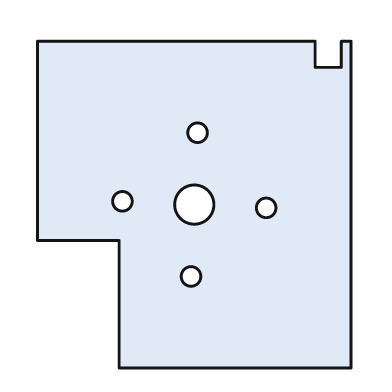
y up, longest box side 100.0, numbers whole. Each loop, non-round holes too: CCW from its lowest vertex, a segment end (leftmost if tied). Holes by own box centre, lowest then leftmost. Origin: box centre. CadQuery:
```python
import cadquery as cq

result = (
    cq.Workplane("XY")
    .moveTo(-23.0, -50.0)
    .lineTo(48.0, -50.0)
    .lineTo(48.0, 50.0)
    .lineTo(45.0, 50.0)
    .lineTo(45.0, 42.0)
    .lineTo(37.0, 42.0)
    .lineTo(37.0, 50.0)
    .lineTo(-48.0, 50.0)
    .lineTo(-48.0, -11.0)
    .lineTo(-23.0, -11.0)
    .close()
    .moveTo(-1.0, -22.0)
    .circle(3.0)
    .moveTo(22.0, -1.0)
    .circle(3.0)
    .moveTo(0.0, 0.0)
    .circle(6.0)
    .moveTo(-22.0, 1.0)
    .circle(3.0)
    .moveTo(1.0, 22.0)
    .circle(3.0)
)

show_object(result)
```